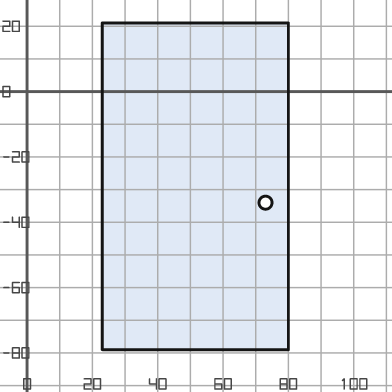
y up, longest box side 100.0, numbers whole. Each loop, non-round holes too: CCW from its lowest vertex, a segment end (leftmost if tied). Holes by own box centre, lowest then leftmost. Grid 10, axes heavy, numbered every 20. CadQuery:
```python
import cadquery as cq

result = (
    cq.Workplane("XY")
    .moveTo(23.0, -79.0)
    .lineTo(80.0, -79.0)
    .lineTo(80.0, 21.0)
    .lineTo(23.0, 21.0)
    .close()
    .moveTo(73.0, -34.0)
    .circle(2.0)
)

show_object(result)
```